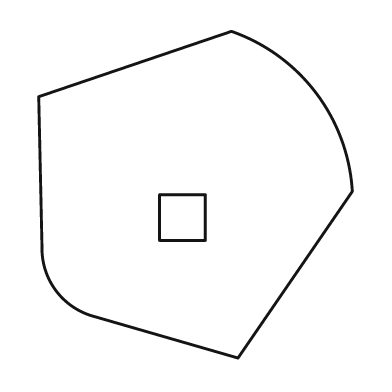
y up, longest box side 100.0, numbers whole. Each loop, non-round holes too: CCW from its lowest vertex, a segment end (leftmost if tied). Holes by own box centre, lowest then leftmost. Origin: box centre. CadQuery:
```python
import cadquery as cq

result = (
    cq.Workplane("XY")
    .moveTo(13.0, -50.0)
    .lineTo(48.0, 1.0)
    .threePointArc((37.0, 31.0), (11.0, 50.0))
    .lineTo(-48.0, 30.0)
    .lineTo(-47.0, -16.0)
    .threePointArc((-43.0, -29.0), (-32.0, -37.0))
    .close()
    .moveTo(-11.0, -14.0)
    .lineTo(3.0, -14.0)
    .lineTo(3.0, 0.0)
    .lineTo(-11.0, 0.0)
    .close()
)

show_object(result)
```